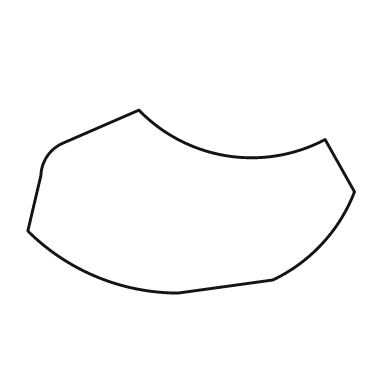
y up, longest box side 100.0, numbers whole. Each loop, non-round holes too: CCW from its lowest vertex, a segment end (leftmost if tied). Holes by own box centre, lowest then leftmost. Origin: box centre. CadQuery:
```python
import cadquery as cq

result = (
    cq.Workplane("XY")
    .moveTo(-4.0, -28.0)
    .lineTo(25.0, -24.0)
    .threePointArc((40.0, -13.0), (50.0, 3.0))
    .lineTo(41.0, 19.0)
    .threePointArc((11.0, 14.0), (-16.0, 28.0))
    .lineTo(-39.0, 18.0)
    .threePointArc((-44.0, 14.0), (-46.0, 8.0))
    .lineTo(-50.0, -9.0)
    .threePointArc((-29.0, -23.0), (-4.0, -28.0))
    .close()
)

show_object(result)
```